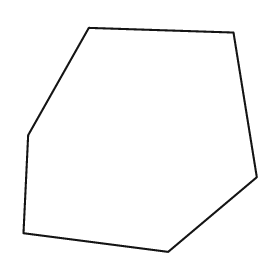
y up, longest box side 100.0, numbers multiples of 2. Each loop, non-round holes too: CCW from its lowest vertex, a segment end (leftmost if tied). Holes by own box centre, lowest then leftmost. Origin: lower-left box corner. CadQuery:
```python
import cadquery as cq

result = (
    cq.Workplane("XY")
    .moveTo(62.0, 0.0)
    .lineTo(100.0, 32.0)
    .lineTo(90.0, 94.0)
    .lineTo(28.0, 96.0)
    .lineTo(2.0, 50.0)
    .lineTo(0.0, 8.0)
    .close()
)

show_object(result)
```